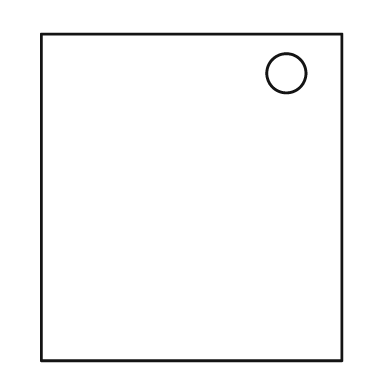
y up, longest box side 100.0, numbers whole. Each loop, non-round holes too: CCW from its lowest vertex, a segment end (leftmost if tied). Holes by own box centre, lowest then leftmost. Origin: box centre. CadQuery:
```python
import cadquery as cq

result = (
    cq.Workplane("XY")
    .moveTo(-46.0, -50.0)
    .lineTo(46.0, -50.0)
    .lineTo(46.0, 50.0)
    .lineTo(-46.0, 50.0)
    .close()
    .moveTo(29.0, 38.0)
    .circle(6.0)
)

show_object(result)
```